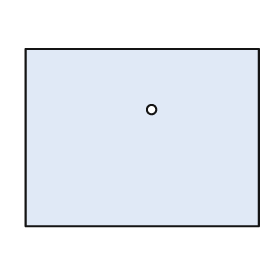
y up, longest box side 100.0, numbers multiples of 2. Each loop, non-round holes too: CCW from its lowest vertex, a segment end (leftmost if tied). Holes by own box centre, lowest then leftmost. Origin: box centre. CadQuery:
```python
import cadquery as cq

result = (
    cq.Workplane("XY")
    .moveTo(-50.0, -38.0)
    .lineTo(50.0, -38.0)
    .lineTo(50.0, 38.0)
    .lineTo(-50.0, 38.0)
    .close()
    .moveTo(4.0, 12.0)
    .circle(2.0)
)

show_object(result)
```